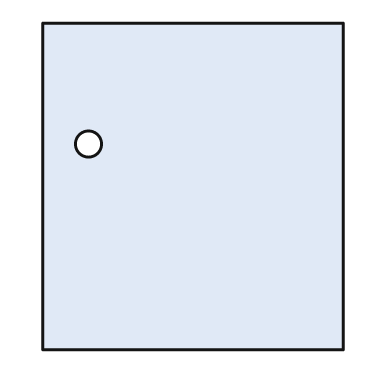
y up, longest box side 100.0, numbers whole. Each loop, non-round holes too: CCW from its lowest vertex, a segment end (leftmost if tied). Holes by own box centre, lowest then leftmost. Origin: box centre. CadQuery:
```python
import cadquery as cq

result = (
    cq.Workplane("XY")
    .moveTo(-46.0, -50.0)
    .lineTo(46.0, -50.0)
    .lineTo(46.0, 50.0)
    .lineTo(-46.0, 50.0)
    .close()
    .moveTo(-32.0, 13.0)
    .circle(4.0)
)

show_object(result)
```